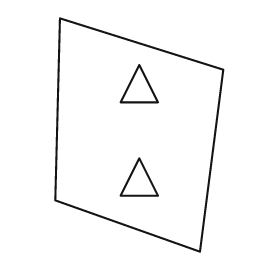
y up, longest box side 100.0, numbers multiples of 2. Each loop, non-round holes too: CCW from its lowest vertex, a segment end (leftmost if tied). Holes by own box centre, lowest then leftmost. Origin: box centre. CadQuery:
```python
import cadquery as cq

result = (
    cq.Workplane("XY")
    .moveTo(26.0, -50.0)
    .lineTo(36.0, 28.0)
    .lineTo(-34.0, 50.0)
    .lineTo(-36.0, -28.0)
    .close()
    .moveTo(-8.0, -26.0)
    .lineTo(8.0, -26.0)
    .lineTo(0.0, -10.0)
    .close()
    .moveTo(-8.0, 14.0)
    .lineTo(8.0, 14.0)
    .lineTo(0.0, 30.0)
    .close()
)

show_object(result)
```